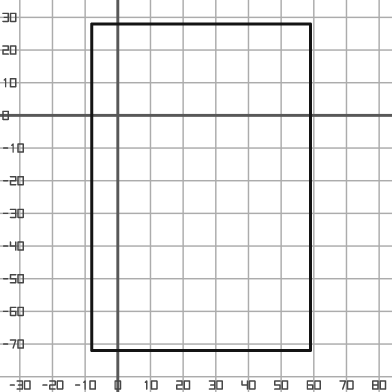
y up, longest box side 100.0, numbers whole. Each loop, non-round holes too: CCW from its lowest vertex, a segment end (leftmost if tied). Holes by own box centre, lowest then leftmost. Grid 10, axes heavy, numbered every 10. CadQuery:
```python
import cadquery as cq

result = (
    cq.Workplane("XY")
    .moveTo(-8.0, -72.0)
    .lineTo(59.0, -72.0)
    .lineTo(59.0, 28.0)
    .lineTo(-8.0, 28.0)
    .close()
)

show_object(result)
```